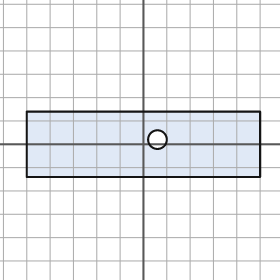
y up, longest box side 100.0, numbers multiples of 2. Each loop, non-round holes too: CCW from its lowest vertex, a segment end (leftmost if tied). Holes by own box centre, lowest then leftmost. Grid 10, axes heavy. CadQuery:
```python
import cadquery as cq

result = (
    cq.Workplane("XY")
    .moveTo(-50.0, -14.0)
    .lineTo(50.0, -14.0)
    .lineTo(50.0, 14.0)
    .lineTo(-50.0, 14.0)
    .close()
    .moveTo(6.0, 2.0)
    .circle(4.0)
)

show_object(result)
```